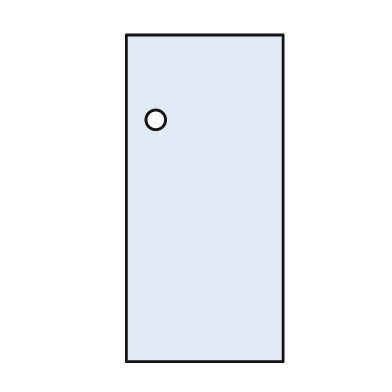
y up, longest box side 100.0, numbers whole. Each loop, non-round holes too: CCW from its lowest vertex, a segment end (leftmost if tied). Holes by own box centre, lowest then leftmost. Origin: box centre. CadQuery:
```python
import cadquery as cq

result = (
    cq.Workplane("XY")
    .moveTo(-24.0, -50.0)
    .lineTo(24.0, -50.0)
    .lineTo(24.0, 50.0)
    .lineTo(-24.0, 50.0)
    .close()
    .moveTo(-15.0, 24.0)
    .circle(3.0)
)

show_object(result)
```